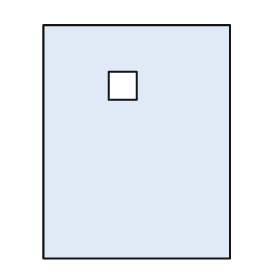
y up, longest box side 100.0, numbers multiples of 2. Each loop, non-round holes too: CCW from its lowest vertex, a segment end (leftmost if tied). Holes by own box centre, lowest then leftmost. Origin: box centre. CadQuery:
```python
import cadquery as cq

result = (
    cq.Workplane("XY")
    .moveTo(-40.0, -50.0)
    .lineTo(40.0, -50.0)
    .lineTo(40.0, 50.0)
    .lineTo(-40.0, 50.0)
    .close()
    .moveTo(-12.0, 18.0)
    .lineTo(0.0, 18.0)
    .lineTo(0.0, 30.0)
    .lineTo(-12.0, 30.0)
    .close()
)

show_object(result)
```